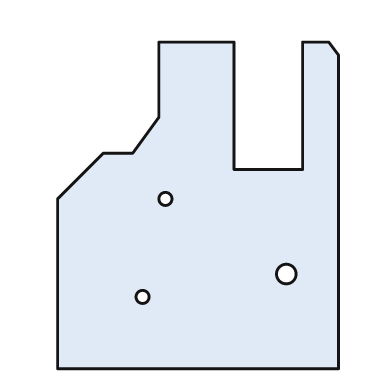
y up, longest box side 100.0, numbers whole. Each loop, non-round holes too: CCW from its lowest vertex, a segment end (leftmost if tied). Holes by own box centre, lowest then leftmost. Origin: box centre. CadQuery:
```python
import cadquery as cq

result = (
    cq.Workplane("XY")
    .moveTo(-43.0, -50.0)
    .lineTo(43.0, -50.0)
    .lineTo(43.0, 46.0)
    .lineTo(40.0, 50.0)
    .lineTo(32.0, 50.0)
    .lineTo(32.0, 11.0)
    .lineTo(11.0, 11.0)
    .lineTo(11.0, 50.0)
    .lineTo(-12.0, 50.0)
    .lineTo(-12.0, 27.0)
    .lineTo(-20.0, 16.0)
    .lineTo(-29.0, 16.0)
    .lineTo(-43.0, 2.0)
    .close()
    .moveTo(-17.0, -28.0)
    .circle(2.0)
    .moveTo(27.0, -21.0)
    .circle(3.0)
    .moveTo(-10.0, 2.0)
    .circle(2.0)
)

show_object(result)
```